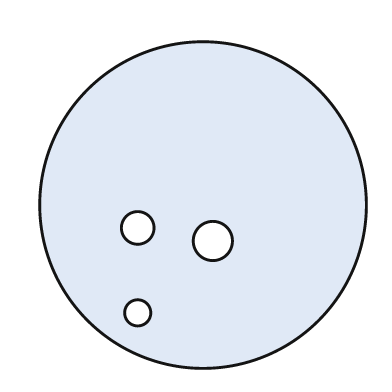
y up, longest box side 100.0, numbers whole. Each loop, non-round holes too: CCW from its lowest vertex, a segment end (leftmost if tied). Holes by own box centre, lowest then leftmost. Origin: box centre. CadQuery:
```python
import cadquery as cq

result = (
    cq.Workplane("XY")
    .moveTo(0.0, 0.0)
    .circle(50.0)
    .moveTo(-20.0, -33.0)
    .circle(4.0)
    .moveTo(3.0, -11.0)
    .circle(6.0)
    .moveTo(-20.0, -7.0)
    .circle(5.0)
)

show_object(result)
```